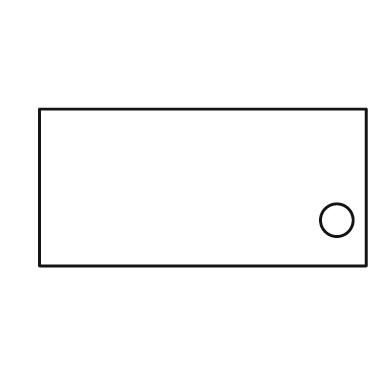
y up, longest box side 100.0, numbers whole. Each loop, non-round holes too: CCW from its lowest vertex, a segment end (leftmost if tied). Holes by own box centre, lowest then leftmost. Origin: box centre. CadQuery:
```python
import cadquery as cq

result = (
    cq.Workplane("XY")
    .moveTo(-50.0, -24.0)
    .lineTo(50.0, -24.0)
    .lineTo(50.0, 24.0)
    .lineTo(-50.0, 24.0)
    .close()
    .moveTo(41.0, -10.0)
    .circle(5.0)
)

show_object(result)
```